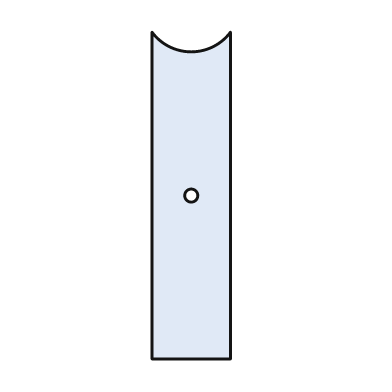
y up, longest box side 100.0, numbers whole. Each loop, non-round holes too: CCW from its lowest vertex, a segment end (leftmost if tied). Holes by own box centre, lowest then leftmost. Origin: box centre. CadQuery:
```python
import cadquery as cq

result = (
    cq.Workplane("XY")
    .moveTo(-12.0, -50.0)
    .lineTo(12.0, -50.0)
    .lineTo(12.0, 50.0)
    .threePointArc((0.0, 44.0), (-12.0, 50.0))
    .close()
    .moveTo(0.0, 0.0)
    .circle(2.0)
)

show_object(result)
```